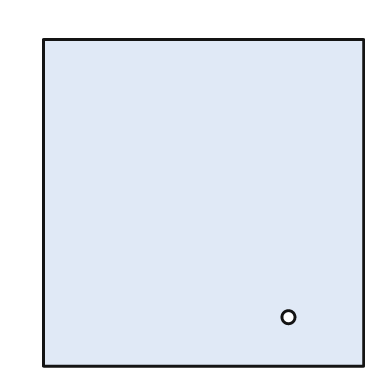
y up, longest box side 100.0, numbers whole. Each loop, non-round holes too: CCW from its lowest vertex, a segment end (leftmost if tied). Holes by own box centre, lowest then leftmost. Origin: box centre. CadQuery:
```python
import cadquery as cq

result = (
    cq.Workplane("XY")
    .moveTo(-49.0, -50.0)
    .lineTo(49.0, -50.0)
    .lineTo(49.0, 50.0)
    .lineTo(-49.0, 50.0)
    .close()
    .moveTo(26.0, -35.0)
    .circle(2.0)
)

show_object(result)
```